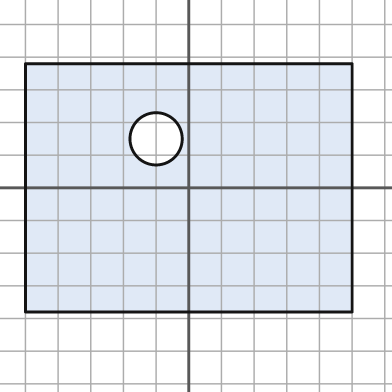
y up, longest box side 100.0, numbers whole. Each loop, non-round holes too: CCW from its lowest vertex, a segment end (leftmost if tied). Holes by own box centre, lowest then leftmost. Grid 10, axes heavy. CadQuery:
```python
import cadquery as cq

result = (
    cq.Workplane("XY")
    .moveTo(-50.0, -38.0)
    .lineTo(50.0, -38.0)
    .lineTo(50.0, 38.0)
    .lineTo(-50.0, 38.0)
    .close()
    .moveTo(-10.0, 15.0)
    .circle(8.0)
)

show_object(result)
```